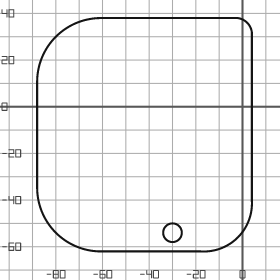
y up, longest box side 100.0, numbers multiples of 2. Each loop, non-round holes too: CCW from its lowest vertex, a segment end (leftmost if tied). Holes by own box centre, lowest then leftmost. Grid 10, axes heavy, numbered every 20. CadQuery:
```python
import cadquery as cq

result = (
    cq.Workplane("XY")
    .moveTo(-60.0, -62.0)
    .lineTo(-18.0, -62.0)
    .threePointArc((-2.0, -56.0), (4.0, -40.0))
    .lineTo(4.0, 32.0)
    .threePointArc((2.0, 36.0), (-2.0, 38.0))
    .lineTo(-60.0, 38.0)
    .threePointArc((-80.0, 30.0), (-88.0, 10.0))
    .lineTo(-88.0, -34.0)
    .threePointArc((-80.0, -54.0), (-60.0, -62.0))
    .close()
    .moveTo(-30.0, -54.0)
    .circle(4.0)
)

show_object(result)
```